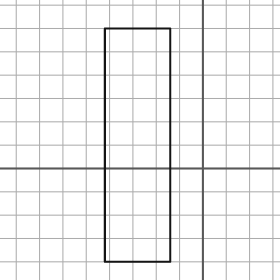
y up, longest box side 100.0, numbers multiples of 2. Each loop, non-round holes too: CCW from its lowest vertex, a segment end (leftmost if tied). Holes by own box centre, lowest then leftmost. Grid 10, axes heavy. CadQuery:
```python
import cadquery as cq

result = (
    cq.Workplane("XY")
    .moveTo(-42.0, -40.0)
    .lineTo(-14.0, -40.0)
    .lineTo(-14.0, 60.0)
    .lineTo(-42.0, 60.0)
    .close()
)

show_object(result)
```